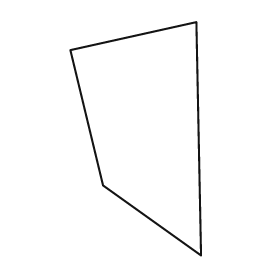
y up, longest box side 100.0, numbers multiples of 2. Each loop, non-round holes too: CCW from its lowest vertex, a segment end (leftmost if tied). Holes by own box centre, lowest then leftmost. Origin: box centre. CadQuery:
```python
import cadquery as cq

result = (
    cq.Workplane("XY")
    .moveTo(28.0, -50.0)
    .lineTo(26.0, 50.0)
    .lineTo(-28.0, 38.0)
    .lineTo(-14.0, -20.0)
    .close()
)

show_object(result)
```